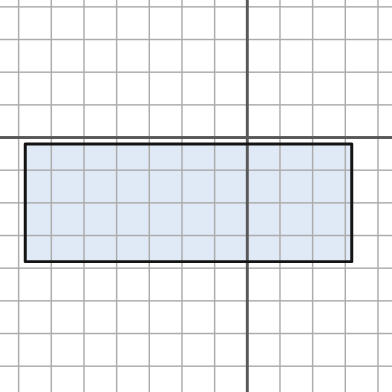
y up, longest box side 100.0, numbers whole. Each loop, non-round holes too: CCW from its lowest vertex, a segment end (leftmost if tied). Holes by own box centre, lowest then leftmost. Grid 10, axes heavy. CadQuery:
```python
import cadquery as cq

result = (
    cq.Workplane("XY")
    .moveTo(-68.0, -38.0)
    .lineTo(32.0, -38.0)
    .lineTo(32.0, -2.0)
    .lineTo(-68.0, -2.0)
    .close()
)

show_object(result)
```